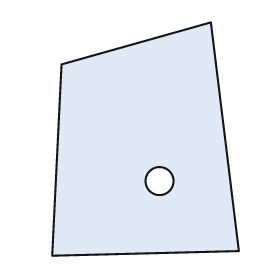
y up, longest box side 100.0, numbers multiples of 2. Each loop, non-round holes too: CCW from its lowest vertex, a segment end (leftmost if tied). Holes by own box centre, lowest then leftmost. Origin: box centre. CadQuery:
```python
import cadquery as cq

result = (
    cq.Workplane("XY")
    .moveTo(-40.0, -50.0)
    .lineTo(40.0, -48.0)
    .lineTo(28.0, 50.0)
    .lineTo(-36.0, 32.0)
    .close()
    .moveTo(6.0, -18.0)
    .circle(6.0)
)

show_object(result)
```